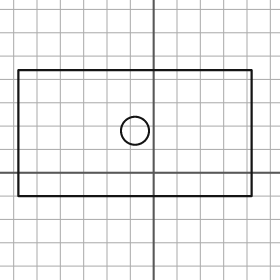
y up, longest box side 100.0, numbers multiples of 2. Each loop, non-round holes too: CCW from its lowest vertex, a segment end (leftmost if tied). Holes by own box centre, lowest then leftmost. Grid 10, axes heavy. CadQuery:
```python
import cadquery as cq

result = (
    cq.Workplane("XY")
    .moveTo(-58.0, -10.0)
    .lineTo(42.0, -10.0)
    .lineTo(42.0, 44.0)
    .lineTo(-58.0, 44.0)
    .close()
    .moveTo(-8.0, 18.0)
    .circle(6.0)
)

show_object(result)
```